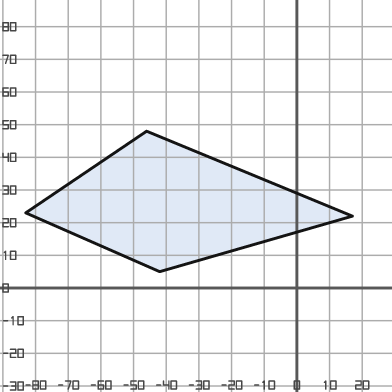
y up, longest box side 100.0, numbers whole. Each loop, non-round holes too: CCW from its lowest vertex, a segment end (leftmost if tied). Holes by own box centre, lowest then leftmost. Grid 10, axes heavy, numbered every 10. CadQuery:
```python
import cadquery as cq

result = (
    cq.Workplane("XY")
    .moveTo(-42.0, 5.0)
    .lineTo(17.0, 22.0)
    .lineTo(-46.0, 48.0)
    .lineTo(-83.0, 23.0)
    .close()
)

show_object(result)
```